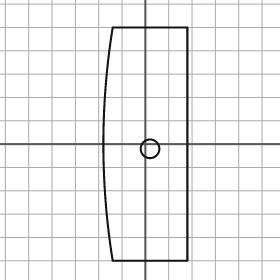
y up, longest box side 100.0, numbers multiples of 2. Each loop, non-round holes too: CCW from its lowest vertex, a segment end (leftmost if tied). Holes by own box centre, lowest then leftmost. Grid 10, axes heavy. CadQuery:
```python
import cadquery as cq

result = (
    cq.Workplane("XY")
    .moveTo(-14.0, -50.0)
    .lineTo(18.0, -50.0)
    .lineTo(18.0, 50.0)
    .lineTo(-14.0, 50.0)
    .threePointArc((-18.0, 0.0), (-14.0, -50.0))
    .close()
    .moveTo(2.0, -2.0)
    .circle(4.0)
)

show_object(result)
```